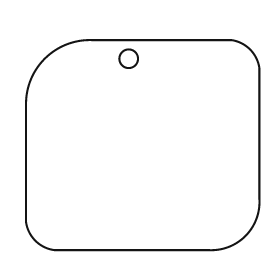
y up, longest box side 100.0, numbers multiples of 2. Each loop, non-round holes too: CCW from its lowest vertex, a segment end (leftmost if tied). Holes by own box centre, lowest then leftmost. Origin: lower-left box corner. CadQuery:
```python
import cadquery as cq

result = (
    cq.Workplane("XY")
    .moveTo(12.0, 0.0)
    .lineTo(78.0, 0.0)
    .threePointArc((94.0, 6.0), (100.0, 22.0))
    .lineTo(100.0, 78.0)
    .threePointArc((96.0, 86.0), (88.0, 90.0))
    .lineTo(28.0, 90.0)
    .threePointArc((8.0, 82.0), (0.0, 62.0))
    .lineTo(0.0, 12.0)
    .threePointArc((4.0, 4.0), (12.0, 0.0))
    .close()
    .moveTo(44.0, 82.0)
    .circle(4.0)
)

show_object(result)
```